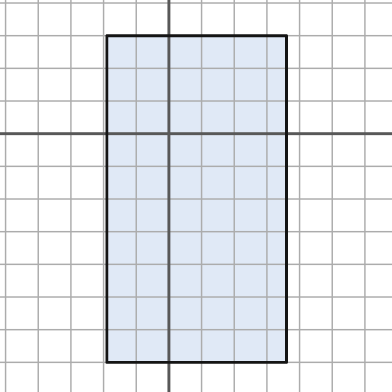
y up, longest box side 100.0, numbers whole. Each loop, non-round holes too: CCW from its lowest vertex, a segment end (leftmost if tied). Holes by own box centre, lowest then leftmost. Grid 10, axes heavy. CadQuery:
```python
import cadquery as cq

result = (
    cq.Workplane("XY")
    .moveTo(-19.0, -70.0)
    .lineTo(36.0, -70.0)
    .lineTo(36.0, 30.0)
    .lineTo(-19.0, 30.0)
    .close()
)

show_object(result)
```